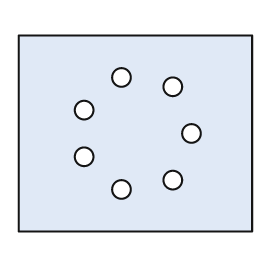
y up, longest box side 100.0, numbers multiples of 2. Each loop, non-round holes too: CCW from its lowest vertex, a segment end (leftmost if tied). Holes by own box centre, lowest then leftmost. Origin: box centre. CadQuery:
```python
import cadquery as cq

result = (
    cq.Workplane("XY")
    .moveTo(-50.0, -42.0)
    .lineTo(50.0, -42.0)
    .lineTo(50.0, 42.0)
    .lineTo(-50.0, 42.0)
    .close()
    .moveTo(-6.0, -24.0)
    .circle(4.0)
    .moveTo(16.0, -20.0)
    .circle(4.0)
    .moveTo(-22.0, -10.0)
    .circle(4.0)
    .moveTo(24.0, 0.0)
    .circle(4.0)
    .moveTo(-22.0, 10.0)
    .circle(4.0)
    .moveTo(16.0, 20.0)
    .circle(4.0)
    .moveTo(-6.0, 24.0)
    .circle(4.0)
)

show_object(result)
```